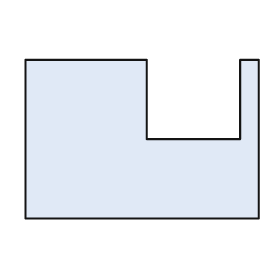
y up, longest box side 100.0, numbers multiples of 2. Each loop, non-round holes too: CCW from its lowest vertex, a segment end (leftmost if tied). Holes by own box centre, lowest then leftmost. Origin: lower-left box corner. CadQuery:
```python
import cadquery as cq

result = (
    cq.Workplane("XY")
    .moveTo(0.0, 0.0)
    .lineTo(100.0, 0.0)
    .lineTo(100.0, 68.0)
    .lineTo(92.0, 68.0)
    .lineTo(92.0, 34.0)
    .lineTo(52.0, 34.0)
    .lineTo(52.0, 68.0)
    .lineTo(0.0, 68.0)
    .close()
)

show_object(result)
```